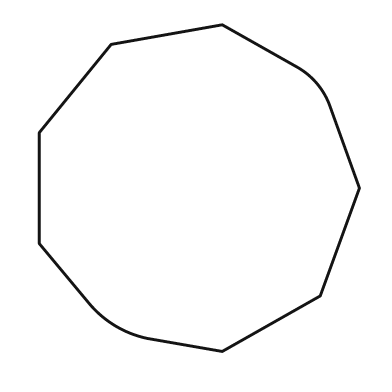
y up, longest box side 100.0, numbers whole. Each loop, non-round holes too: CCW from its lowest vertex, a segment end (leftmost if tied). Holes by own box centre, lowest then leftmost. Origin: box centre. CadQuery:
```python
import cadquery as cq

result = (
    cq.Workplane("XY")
    .moveTo(7.0, -50.0)
    .lineTo(37.0, -33.0)
    .lineTo(49.0, 0.0)
    .lineTo(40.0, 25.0)
    .threePointArc((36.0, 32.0), (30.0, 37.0))
    .lineTo(7.0, 50.0)
    .lineTo(-27.0, 44.0)
    .lineTo(-49.0, 17.0)
    .lineTo(-49.0, -17.0)
    .lineTo(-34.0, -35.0)
    .threePointArc((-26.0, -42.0), (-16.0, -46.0))
    .close()
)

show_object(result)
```